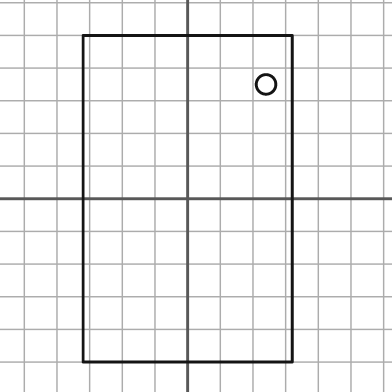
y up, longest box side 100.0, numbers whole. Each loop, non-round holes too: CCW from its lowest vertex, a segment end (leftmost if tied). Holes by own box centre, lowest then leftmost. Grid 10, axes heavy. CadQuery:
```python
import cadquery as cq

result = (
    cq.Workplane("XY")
    .moveTo(-32.0, -50.0)
    .lineTo(32.0, -50.0)
    .lineTo(32.0, 50.0)
    .lineTo(-32.0, 50.0)
    .close()
    .moveTo(24.0, 35.0)
    .circle(3.0)
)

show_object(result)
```